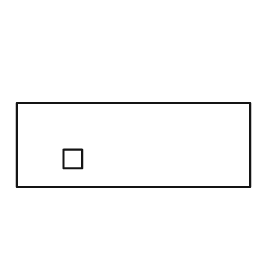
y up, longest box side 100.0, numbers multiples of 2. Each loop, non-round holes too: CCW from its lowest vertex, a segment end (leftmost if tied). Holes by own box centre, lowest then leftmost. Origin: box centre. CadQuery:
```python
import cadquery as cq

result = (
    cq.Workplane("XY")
    .moveTo(-50.0, -18.0)
    .lineTo(50.0, -18.0)
    .lineTo(50.0, 18.0)
    .lineTo(-50.0, 18.0)
    .close()
    .moveTo(-30.0, -10.0)
    .lineTo(-22.0, -10.0)
    .lineTo(-22.0, -2.0)
    .lineTo(-30.0, -2.0)
    .close()
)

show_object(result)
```